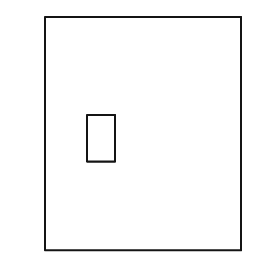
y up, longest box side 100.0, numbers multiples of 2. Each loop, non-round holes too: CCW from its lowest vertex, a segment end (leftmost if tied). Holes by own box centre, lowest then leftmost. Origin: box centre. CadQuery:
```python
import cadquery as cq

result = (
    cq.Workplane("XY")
    .moveTo(-42.0, -50.0)
    .lineTo(42.0, -50.0)
    .lineTo(42.0, 50.0)
    .lineTo(-42.0, 50.0)
    .close()
    .moveTo(-24.0, -12.0)
    .lineTo(-12.0, -12.0)
    .lineTo(-12.0, 8.0)
    .lineTo(-24.0, 8.0)
    .close()
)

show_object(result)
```